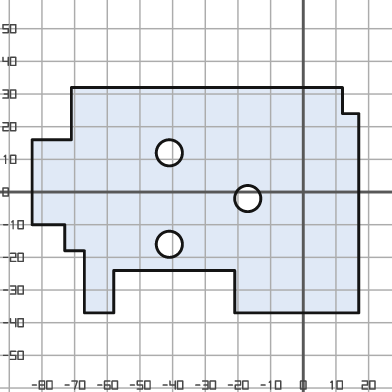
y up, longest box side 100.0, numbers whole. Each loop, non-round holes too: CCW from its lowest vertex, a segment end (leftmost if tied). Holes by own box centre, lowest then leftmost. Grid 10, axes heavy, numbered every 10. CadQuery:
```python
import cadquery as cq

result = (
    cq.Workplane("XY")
    .moveTo(-67.0, -37.0)
    .lineTo(-58.0, -37.0)
    .lineTo(-58.0, -24.0)
    .lineTo(-21.0, -24.0)
    .lineTo(-21.0, -37.0)
    .lineTo(17.0, -37.0)
    .lineTo(17.0, 24.0)
    .lineTo(12.0, 24.0)
    .lineTo(12.0, 32.0)
    .lineTo(-71.0, 32.0)
    .lineTo(-71.0, 16.0)
    .lineTo(-83.0, 16.0)
    .lineTo(-83.0, -10.0)
    .lineTo(-73.0, -10.0)
    .lineTo(-73.0, -18.0)
    .lineTo(-67.0, -18.0)
    .close()
    .moveTo(-41.0, -16.0)
    .circle(4.0)
    .moveTo(-17.0, -2.0)
    .circle(4.0)
    .moveTo(-41.0, 12.0)
    .circle(4.0)
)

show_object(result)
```